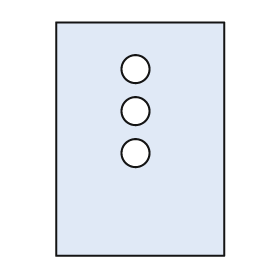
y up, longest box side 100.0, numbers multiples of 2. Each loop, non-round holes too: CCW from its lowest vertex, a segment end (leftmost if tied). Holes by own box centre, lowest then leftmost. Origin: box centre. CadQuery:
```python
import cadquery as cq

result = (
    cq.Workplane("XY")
    .moveTo(-36.0, -50.0)
    .lineTo(36.0, -50.0)
    .lineTo(36.0, 50.0)
    .lineTo(-36.0, 50.0)
    .close()
    .moveTo(-2.0, -6.0)
    .circle(6.0)
    .moveTo(-2.0, 12.0)
    .circle(6.0)
    .moveTo(-2.0, 30.0)
    .circle(6.0)
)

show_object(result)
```